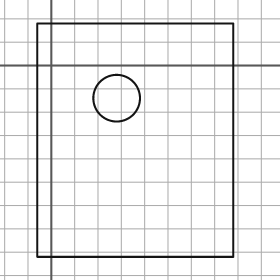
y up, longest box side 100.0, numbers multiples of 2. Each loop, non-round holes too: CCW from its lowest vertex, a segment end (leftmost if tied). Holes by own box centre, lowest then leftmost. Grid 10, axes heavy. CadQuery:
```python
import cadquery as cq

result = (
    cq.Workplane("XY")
    .moveTo(-6.0, -82.0)
    .lineTo(78.0, -82.0)
    .lineTo(78.0, 18.0)
    .lineTo(-6.0, 18.0)
    .close()
    .moveTo(28.0, -14.0)
    .circle(10.0)
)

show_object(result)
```